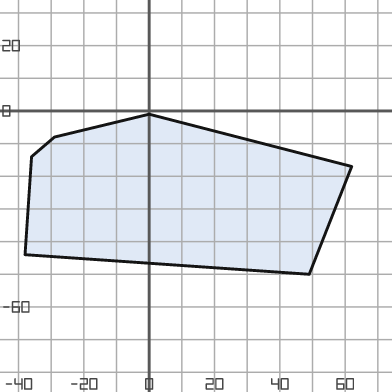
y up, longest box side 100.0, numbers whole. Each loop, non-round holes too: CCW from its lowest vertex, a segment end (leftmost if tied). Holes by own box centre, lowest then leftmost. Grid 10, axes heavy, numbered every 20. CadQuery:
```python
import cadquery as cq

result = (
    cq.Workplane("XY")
    .moveTo(49.0, -50.0)
    .lineTo(62.0, -17.0)
    .lineTo(0.0, -1.0)
    .lineTo(-29.0, -8.0)
    .lineTo(-36.0, -14.0)
    .lineTo(-38.0, -44.0)
    .close()
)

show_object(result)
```